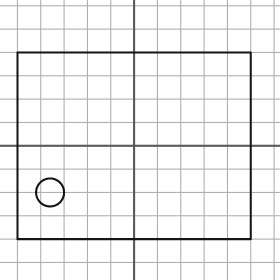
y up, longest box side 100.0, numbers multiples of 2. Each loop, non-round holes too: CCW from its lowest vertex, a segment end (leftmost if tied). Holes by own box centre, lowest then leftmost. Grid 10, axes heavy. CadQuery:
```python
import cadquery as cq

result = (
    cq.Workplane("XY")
    .moveTo(-50.0, -40.0)
    .lineTo(50.0, -40.0)
    .lineTo(50.0, 40.0)
    .lineTo(-50.0, 40.0)
    .close()
    .moveTo(-36.0, -20.0)
    .circle(6.0)
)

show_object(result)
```